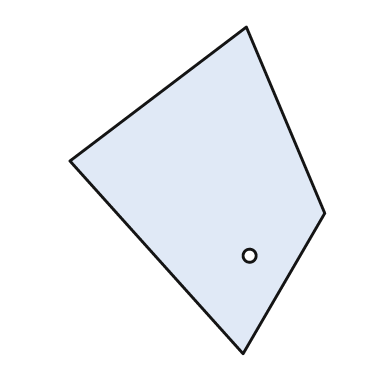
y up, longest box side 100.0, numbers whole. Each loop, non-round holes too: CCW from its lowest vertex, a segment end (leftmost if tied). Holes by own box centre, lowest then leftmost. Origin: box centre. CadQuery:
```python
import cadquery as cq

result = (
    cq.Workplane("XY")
    .moveTo(14.0, -50.0)
    .lineTo(39.0, -7.0)
    .lineTo(15.0, 50.0)
    .lineTo(-39.0, 9.0)
    .close()
    .moveTo(16.0, -20.0)
    .circle(2.0)
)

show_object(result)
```